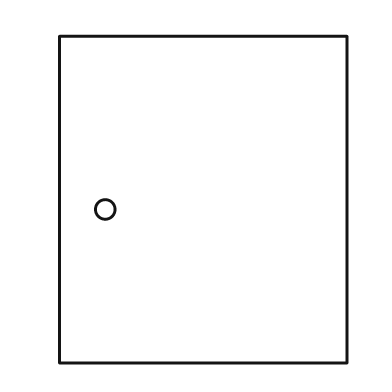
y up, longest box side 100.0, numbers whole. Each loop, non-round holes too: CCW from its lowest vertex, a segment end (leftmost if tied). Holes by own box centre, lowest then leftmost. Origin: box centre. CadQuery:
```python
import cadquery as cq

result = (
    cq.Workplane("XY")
    .moveTo(-44.0, -50.0)
    .lineTo(44.0, -50.0)
    .lineTo(44.0, 50.0)
    .lineTo(-44.0, 50.0)
    .close()
    .moveTo(-30.0, -3.0)
    .circle(3.0)
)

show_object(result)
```